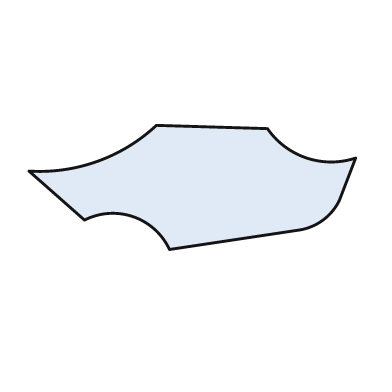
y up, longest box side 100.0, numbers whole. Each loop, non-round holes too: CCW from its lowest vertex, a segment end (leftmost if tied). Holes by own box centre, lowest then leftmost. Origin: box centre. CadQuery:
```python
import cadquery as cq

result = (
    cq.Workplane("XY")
    .moveTo(-7.0, -19.0)
    .lineTo(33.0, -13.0)
    .threePointArc((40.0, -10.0), (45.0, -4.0))
    .lineTo(50.0, 9.0)
    .threePointArc((35.0, 9.0), (23.0, 18.0))
    .lineTo(-11.0, 19.0)
    .threePointArc((-29.0, 8.0), (-50.0, 5.0))
    .lineTo(-33.0, -10.0)
    .threePointArc((-18.0, -9.0), (-7.0, -19.0))
    .close()
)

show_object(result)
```